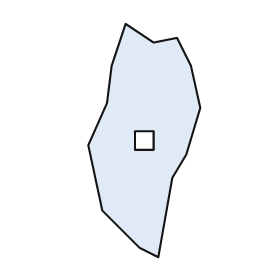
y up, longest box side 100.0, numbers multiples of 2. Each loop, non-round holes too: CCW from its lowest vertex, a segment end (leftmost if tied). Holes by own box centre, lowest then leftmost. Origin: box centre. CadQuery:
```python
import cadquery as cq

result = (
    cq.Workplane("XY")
    .moveTo(6.0, -50.0)
    .lineTo(12.0, -16.0)
    .lineTo(18.0, -6.0)
    .lineTo(24.0, 14.0)
    .lineTo(20.0, 32.0)
    .lineTo(14.0, 44.0)
    .lineTo(4.0, 42.0)
    .lineTo(-8.0, 50.0)
    .lineTo(-14.0, 32.0)
    .lineTo(-16.0, 16.0)
    .lineTo(-24.0, -2.0)
    .lineTo(-18.0, -30.0)
    .lineTo(-2.0, -46.0)
    .close()
    .moveTo(-4.0, -4.0)
    .lineTo(4.0, -4.0)
    .lineTo(4.0, 4.0)
    .lineTo(-4.0, 4.0)
    .close()
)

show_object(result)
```